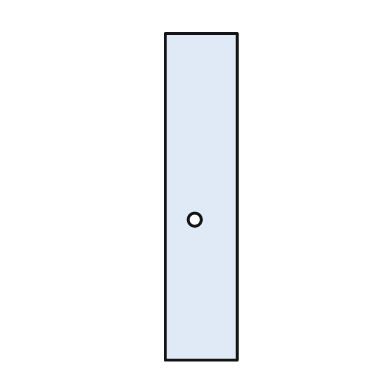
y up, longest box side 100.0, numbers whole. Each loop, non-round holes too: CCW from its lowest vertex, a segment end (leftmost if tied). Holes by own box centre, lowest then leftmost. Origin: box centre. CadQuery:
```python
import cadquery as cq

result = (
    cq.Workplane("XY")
    .moveTo(-11.0, -50.0)
    .lineTo(11.0, -50.0)
    .lineTo(11.0, 50.0)
    .lineTo(-11.0, 50.0)
    .close()
    .moveTo(-2.0, -7.0)
    .circle(2.0)
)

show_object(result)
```